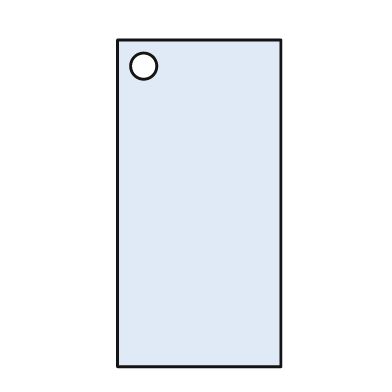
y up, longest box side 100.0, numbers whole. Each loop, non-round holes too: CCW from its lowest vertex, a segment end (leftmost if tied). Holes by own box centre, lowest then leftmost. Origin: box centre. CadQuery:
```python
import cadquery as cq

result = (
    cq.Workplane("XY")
    .moveTo(-25.0, -50.0)
    .lineTo(25.0, -50.0)
    .lineTo(25.0, 50.0)
    .lineTo(-25.0, 50.0)
    .close()
    .moveTo(-17.0, 42.0)
    .circle(4.0)
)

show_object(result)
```